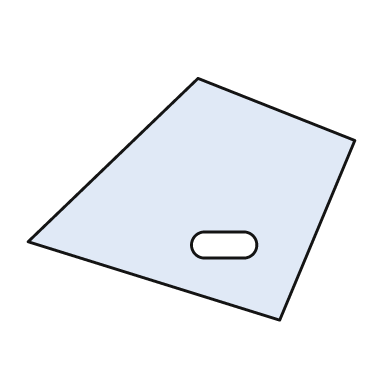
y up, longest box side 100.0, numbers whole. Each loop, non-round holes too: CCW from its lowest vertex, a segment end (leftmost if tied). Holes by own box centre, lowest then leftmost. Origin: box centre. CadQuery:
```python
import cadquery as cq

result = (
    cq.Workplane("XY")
    .moveTo(27.0, -37.0)
    .lineTo(50.0, 18.0)
    .lineTo(2.0, 37.0)
    .lineTo(-50.0, -13.0)
    .close()
    .moveTo(4.0, -18.0)
    .lineTo(16.0, -18.0)
    .threePointArc((20.0, -14.0), (16.0, -10.0))
    .lineTo(4.0, -10.0)
    .threePointArc((0.0, -14.0), (4.0, -18.0))
    .close()
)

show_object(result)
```